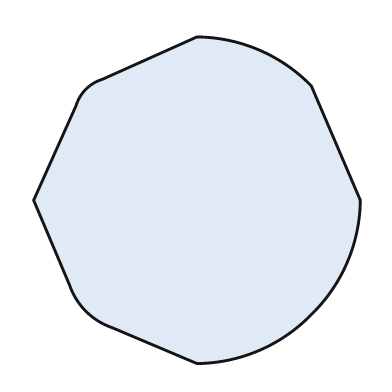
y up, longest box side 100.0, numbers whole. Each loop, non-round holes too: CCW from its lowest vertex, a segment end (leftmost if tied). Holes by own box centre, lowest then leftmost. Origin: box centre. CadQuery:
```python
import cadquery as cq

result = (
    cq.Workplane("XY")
    .moveTo(0.0, -50.0)
    .threePointArc((19.0, -46.0), (35.0, -35.0))
    .threePointArc((46.0, -19.0), (50.0, 0.0))
    .lineTo(35.0, 35.0)
    .threePointArc((19.0, 46.0), (0.0, 50.0))
    .lineTo(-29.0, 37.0)
    .threePointArc((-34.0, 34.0), (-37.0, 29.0))
    .lineTo(-50.0, 0.0)
    .lineTo(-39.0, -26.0)
    .threePointArc((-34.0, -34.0), (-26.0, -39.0))
    .close()
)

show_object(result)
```